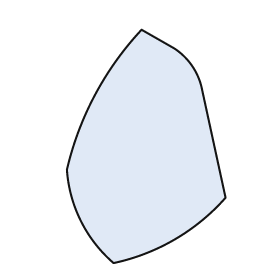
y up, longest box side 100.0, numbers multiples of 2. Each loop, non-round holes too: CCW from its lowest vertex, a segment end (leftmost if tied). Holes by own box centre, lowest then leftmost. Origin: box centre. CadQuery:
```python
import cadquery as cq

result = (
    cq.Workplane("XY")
    .moveTo(-14.0, -50.0)
    .threePointArc((12.0, -40.0), (34.0, -22.0))
    .lineTo(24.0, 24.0)
    .threePointArc((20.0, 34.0), (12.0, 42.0))
    .lineTo(-2.0, 50.0)
    .threePointArc((-22.0, 22.0), (-34.0, -10.0))
    .threePointArc((-28.0, -32.0), (-14.0, -50.0))
    .close()
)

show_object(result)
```